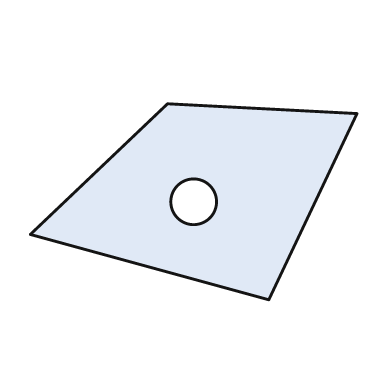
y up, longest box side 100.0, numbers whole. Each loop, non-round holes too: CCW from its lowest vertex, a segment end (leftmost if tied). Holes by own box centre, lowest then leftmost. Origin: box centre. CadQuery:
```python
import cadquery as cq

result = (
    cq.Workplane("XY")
    .moveTo(23.0, -30.0)
    .lineTo(50.0, 27.0)
    .lineTo(-8.0, 30.0)
    .lineTo(-50.0, -10.0)
    .close()
    .moveTo(0.0, 0.0)
    .circle(7.0)
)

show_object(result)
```